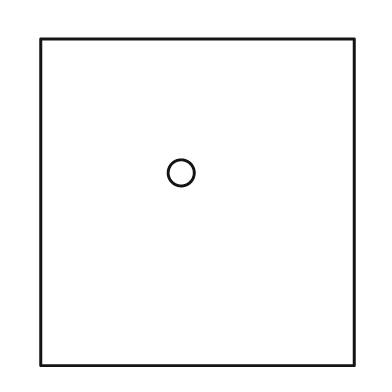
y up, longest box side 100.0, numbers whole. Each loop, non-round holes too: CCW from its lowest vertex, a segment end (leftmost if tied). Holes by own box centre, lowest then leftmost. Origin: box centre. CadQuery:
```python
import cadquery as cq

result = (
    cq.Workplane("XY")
    .moveTo(-48.0, -50.0)
    .lineTo(48.0, -50.0)
    .lineTo(48.0, 50.0)
    .lineTo(-48.0, 50.0)
    .close()
    .moveTo(-5.0, 9.0)
    .circle(4.0)
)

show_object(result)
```